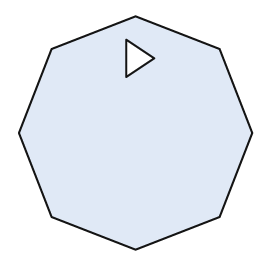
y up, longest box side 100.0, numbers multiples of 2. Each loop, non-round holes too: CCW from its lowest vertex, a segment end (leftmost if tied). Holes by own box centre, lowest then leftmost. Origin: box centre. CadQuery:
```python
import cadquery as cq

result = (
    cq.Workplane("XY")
    .moveTo(0.0, -50.0)
    .lineTo(36.0, -36.0)
    .lineTo(50.0, 0.0)
    .lineTo(36.0, 36.0)
    .lineTo(0.0, 50.0)
    .lineTo(-36.0, 36.0)
    .lineTo(-50.0, 0.0)
    .lineTo(-36.0, -36.0)
    .close()
    .moveTo(-4.0, 24.0)
    .lineTo(8.0, 32.0)
    .lineTo(-4.0, 40.0)
    .close()
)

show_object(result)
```